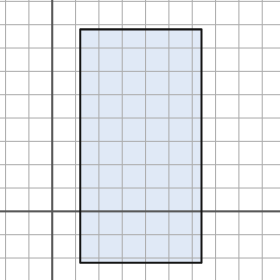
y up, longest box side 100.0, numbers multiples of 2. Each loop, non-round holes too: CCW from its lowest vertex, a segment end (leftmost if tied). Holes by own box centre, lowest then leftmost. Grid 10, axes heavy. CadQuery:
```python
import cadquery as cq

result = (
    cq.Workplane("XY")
    .moveTo(12.0, -22.0)
    .lineTo(64.0, -22.0)
    .lineTo(64.0, 78.0)
    .lineTo(12.0, 78.0)
    .close()
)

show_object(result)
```